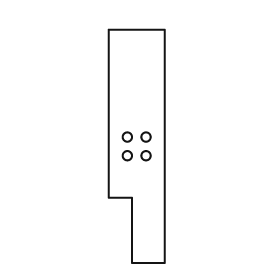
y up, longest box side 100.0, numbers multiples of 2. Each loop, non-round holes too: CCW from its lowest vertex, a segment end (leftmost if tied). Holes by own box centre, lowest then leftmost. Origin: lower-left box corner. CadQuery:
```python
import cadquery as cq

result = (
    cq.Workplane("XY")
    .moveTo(10.0, 0.0)
    .lineTo(24.0, 0.0)
    .lineTo(24.0, 100.0)
    .lineTo(0.0, 100.0)
    .lineTo(0.0, 28.0)
    .lineTo(10.0, 28.0)
    .close()
    .moveTo(8.0, 46.0)
    .circle(2.0)
    .moveTo(16.0, 46.0)
    .circle(2.0)
    .moveTo(8.0, 54.0)
    .circle(2.0)
    .moveTo(16.0, 54.0)
    .circle(2.0)
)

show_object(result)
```